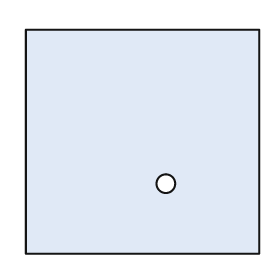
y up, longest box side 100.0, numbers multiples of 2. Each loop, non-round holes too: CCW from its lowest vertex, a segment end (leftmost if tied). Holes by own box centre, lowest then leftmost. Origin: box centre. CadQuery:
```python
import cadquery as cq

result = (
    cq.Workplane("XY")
    .moveTo(-50.0, -48.0)
    .lineTo(50.0, -48.0)
    .lineTo(50.0, 48.0)
    .lineTo(-50.0, 48.0)
    .close()
    .moveTo(10.0, -18.0)
    .circle(4.0)
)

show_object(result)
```